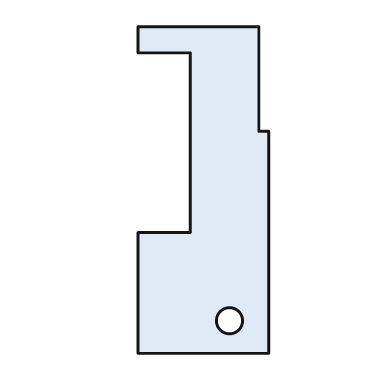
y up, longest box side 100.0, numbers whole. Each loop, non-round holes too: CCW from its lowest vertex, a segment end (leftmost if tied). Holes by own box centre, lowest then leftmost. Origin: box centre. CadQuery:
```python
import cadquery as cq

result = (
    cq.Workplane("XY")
    .moveTo(-20.0, -50.0)
    .lineTo(20.0, -50.0)
    .lineTo(20.0, 18.0)
    .lineTo(17.0, 18.0)
    .lineTo(17.0, 50.0)
    .lineTo(-20.0, 50.0)
    .lineTo(-20.0, 42.0)
    .lineTo(-4.0, 42.0)
    .lineTo(-4.0, -13.0)
    .lineTo(-20.0, -13.0)
    .close()
    .moveTo(8.0, -40.0)
    .circle(4.0)
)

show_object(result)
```